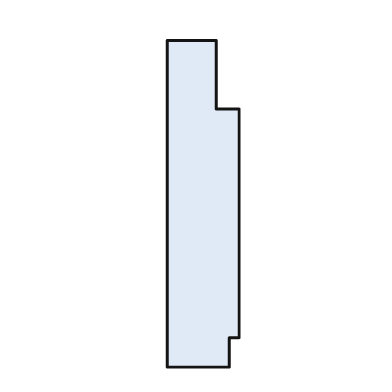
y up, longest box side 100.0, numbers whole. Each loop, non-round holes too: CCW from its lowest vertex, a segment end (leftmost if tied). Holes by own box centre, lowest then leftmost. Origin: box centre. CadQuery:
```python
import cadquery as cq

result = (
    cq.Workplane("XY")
    .moveTo(-11.0, -50.0)
    .lineTo(8.0, -50.0)
    .lineTo(8.0, -41.0)
    .lineTo(11.0, -41.0)
    .lineTo(11.0, 29.0)
    .lineTo(4.0, 29.0)
    .lineTo(4.0, 50.0)
    .lineTo(-11.0, 50.0)
    .close()
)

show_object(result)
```